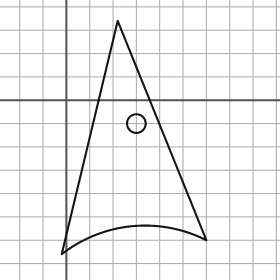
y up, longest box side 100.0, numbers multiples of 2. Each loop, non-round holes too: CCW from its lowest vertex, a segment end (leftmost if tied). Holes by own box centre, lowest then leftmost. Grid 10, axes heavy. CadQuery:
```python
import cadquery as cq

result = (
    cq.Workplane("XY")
    .moveTo(-2.0, -66.0)
    .threePointArc((28.0, -54.0), (60.0, -60.0))
    .lineTo(22.0, 34.0)
    .close()
    .moveTo(30.0, -10.0)
    .circle(4.0)
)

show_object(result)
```